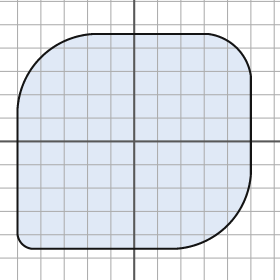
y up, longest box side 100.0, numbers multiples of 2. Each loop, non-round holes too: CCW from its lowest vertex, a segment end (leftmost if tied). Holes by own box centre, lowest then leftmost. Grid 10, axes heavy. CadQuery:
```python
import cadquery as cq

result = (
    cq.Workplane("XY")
    .moveTo(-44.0, -46.0)
    .lineTo(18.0, -46.0)
    .threePointArc((40.0, -36.0), (50.0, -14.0))
    .lineTo(50.0, 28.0)
    .threePointArc((44.0, 40.0), (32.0, 46.0))
    .lineTo(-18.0, 46.0)
    .threePointArc((-40.0, 36.0), (-50.0, 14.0))
    .lineTo(-50.0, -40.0)
    .threePointArc((-48.0, -44.0), (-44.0, -46.0))
    .close()
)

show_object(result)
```